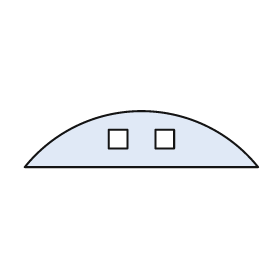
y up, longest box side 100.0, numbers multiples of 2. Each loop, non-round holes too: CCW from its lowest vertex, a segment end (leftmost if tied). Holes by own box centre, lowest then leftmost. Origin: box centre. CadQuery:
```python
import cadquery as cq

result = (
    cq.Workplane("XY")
    .moveTo(-50.0, -12.0)
    .lineTo(50.0, -12.0)
    .threePointArc((0.0, 12.0), (-50.0, -12.0))
    .close()
    .moveTo(-14.0, -4.0)
    .lineTo(-6.0, -4.0)
    .lineTo(-6.0, 4.0)
    .lineTo(-14.0, 4.0)
    .close()
    .moveTo(6.0, -4.0)
    .lineTo(14.0, -4.0)
    .lineTo(14.0, 4.0)
    .lineTo(6.0, 4.0)
    .close()
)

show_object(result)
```